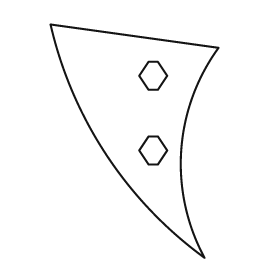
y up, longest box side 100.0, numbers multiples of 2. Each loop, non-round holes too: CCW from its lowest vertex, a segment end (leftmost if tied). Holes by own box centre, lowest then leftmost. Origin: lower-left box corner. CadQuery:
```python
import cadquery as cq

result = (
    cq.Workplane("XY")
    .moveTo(66.0, 0.0)
    .threePointArc((56.0, 46.0), (72.0, 90.0))
    .lineTo(0.0, 100.0)
    .threePointArc((24.0, 44.0), (66.0, 0.0))
    .close()
    .moveTo(42.0, 40.0)
    .lineTo(46.0, 40.0)
    .lineTo(50.0, 46.0)
    .lineTo(46.0, 52.0)
    .lineTo(42.0, 52.0)
    .lineTo(38.0, 46.0)
    .close()
    .moveTo(42.0, 72.0)
    .lineTo(46.0, 72.0)
    .lineTo(50.0, 78.0)
    .lineTo(46.0, 84.0)
    .lineTo(42.0, 84.0)
    .lineTo(38.0, 78.0)
    .close()
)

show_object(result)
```